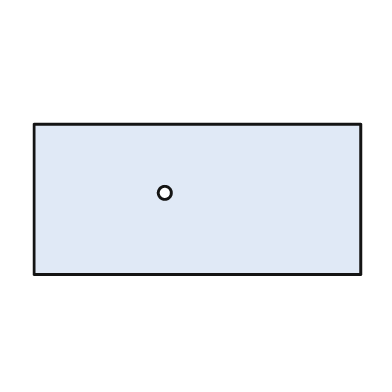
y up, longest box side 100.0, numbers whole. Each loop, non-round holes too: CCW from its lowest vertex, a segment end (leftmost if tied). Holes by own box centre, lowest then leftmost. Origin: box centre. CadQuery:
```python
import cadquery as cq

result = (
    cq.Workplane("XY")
    .moveTo(-50.0, -23.0)
    .lineTo(50.0, -23.0)
    .lineTo(50.0, 23.0)
    .lineTo(-50.0, 23.0)
    .close()
    .moveTo(-10.0, 2.0)
    .circle(2.0)
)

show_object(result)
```